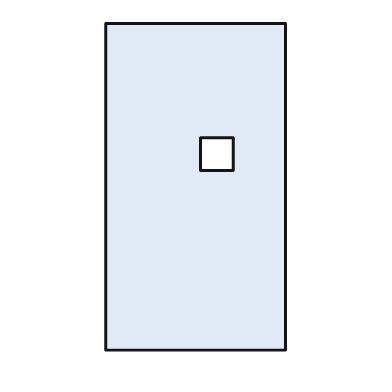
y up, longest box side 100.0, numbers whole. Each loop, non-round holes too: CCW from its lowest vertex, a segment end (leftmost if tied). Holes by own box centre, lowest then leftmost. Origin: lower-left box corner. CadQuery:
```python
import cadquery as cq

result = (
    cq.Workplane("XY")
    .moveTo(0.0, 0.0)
    .lineTo(55.0, 0.0)
    .lineTo(55.0, 100.0)
    .lineTo(0.0, 100.0)
    .close()
    .moveTo(29.0, 55.0)
    .lineTo(39.0, 55.0)
    .lineTo(39.0, 65.0)
    .lineTo(29.0, 65.0)
    .close()
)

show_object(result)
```